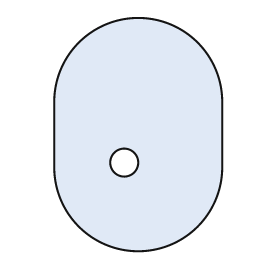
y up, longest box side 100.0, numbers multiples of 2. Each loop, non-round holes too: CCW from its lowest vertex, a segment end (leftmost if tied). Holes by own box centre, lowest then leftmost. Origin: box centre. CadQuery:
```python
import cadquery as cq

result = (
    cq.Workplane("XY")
    .moveTo(-36.0, -14.0)
    .threePointArc((0.0, -50.0), (36.0, -14.0))
    .lineTo(36.0, 14.0)
    .threePointArc((0.0, 50.0), (-36.0, 14.0))
    .close()
    .moveTo(-6.0, -12.0)
    .circle(6.0)
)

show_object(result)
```